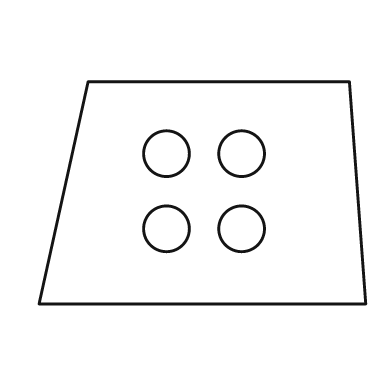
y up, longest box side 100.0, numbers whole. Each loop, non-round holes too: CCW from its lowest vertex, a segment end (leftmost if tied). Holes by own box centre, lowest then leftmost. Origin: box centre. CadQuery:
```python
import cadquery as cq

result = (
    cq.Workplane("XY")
    .moveTo(-50.0, -34.0)
    .lineTo(50.0, -34.0)
    .lineTo(45.0, 34.0)
    .lineTo(-35.0, 34.0)
    .close()
    .moveTo(-11.0, -11.0)
    .circle(7.0)
    .moveTo(12.0, -11.0)
    .circle(7.0)
    .moveTo(-11.0, 12.0)
    .circle(7.0)
    .moveTo(12.0, 12.0)
    .circle(7.0)
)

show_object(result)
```